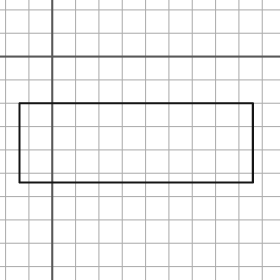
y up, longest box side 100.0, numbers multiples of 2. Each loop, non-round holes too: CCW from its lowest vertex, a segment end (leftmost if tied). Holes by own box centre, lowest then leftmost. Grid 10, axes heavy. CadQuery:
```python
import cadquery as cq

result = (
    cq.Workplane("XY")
    .moveTo(-14.0, -54.0)
    .lineTo(86.0, -54.0)
    .lineTo(86.0, -20.0)
    .lineTo(-14.0, -20.0)
    .close()
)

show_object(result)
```